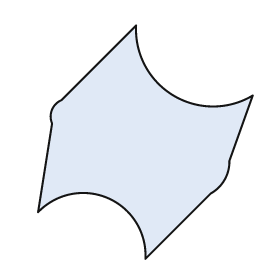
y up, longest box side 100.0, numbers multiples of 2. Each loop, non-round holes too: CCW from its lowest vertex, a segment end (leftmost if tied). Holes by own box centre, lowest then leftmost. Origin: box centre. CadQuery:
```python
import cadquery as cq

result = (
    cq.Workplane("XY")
    .moveTo(0.0, -50.0)
    .lineTo(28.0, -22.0)
    .threePointArc((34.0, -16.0), (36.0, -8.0))
    .lineTo(46.0, 20.0)
    .threePointArc((12.0, 20.0), (-4.0, 50.0))
    .lineTo(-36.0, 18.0)
    .threePointArc((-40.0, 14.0), (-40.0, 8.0))
    .lineTo(-46.0, -30.0)
    .threePointArc((-16.0, -24.0), (0.0, -50.0))
    .close()
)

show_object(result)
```